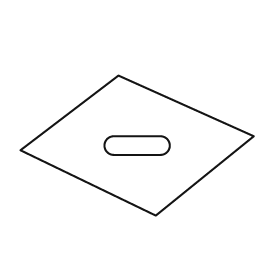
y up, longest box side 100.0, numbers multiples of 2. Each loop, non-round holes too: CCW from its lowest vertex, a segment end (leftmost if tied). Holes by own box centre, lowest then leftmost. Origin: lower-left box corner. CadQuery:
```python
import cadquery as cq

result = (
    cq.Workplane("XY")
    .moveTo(58.0, 0.0)
    .lineTo(100.0, 34.0)
    .lineTo(42.0, 60.0)
    .lineTo(0.0, 28.0)
    .close()
    .moveTo(40.0, 26.0)
    .lineTo(60.0, 26.0)
    .threePointArc((64.0, 30.0), (60.0, 34.0))
    .lineTo(40.0, 34.0)
    .threePointArc((36.0, 30.0), (40.0, 26.0))
    .close()
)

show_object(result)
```